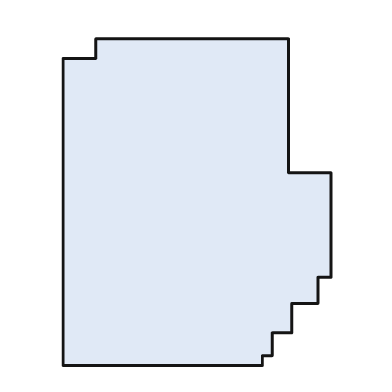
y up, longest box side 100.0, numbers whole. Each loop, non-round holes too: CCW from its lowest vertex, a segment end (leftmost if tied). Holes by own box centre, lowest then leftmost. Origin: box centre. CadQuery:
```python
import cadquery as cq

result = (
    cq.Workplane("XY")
    .moveTo(-41.0, -50.0)
    .lineTo(20.0, -50.0)
    .lineTo(20.0, -47.0)
    .lineTo(23.0, -47.0)
    .lineTo(23.0, -40.0)
    .lineTo(29.0, -40.0)
    .lineTo(29.0, -31.0)
    .lineTo(37.0, -31.0)
    .lineTo(37.0, -23.0)
    .lineTo(41.0, -23.0)
    .lineTo(41.0, 9.0)
    .lineTo(28.0, 9.0)
    .lineTo(28.0, 50.0)
    .lineTo(-31.0, 50.0)
    .lineTo(-31.0, 44.0)
    .lineTo(-41.0, 44.0)
    .close()
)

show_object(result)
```